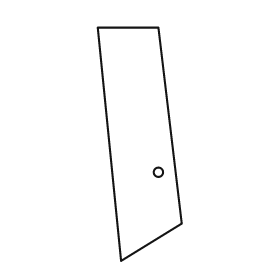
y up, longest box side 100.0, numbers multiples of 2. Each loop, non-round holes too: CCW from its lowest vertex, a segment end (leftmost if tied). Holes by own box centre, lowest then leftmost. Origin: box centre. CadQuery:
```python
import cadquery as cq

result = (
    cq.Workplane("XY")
    .moveTo(-8.0, -50.0)
    .lineTo(18.0, -34.0)
    .lineTo(8.0, 50.0)
    .lineTo(-18.0, 50.0)
    .close()
    .moveTo(8.0, -12.0)
    .circle(2.0)
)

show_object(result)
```